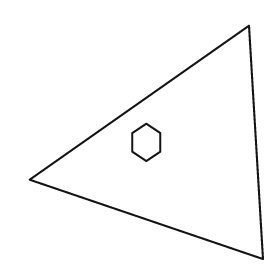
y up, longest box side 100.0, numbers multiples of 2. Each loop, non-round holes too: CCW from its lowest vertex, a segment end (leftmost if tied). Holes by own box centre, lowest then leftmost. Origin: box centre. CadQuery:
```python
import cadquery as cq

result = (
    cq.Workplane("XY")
    .moveTo(50.0, -50.0)
    .lineTo(44.0, 50.0)
    .lineTo(-50.0, -16.0)
    .close()
    .moveTo(0.0, -8.0)
    .lineTo(6.0, -4.0)
    .lineTo(6.0, 4.0)
    .lineTo(0.0, 8.0)
    .lineTo(-6.0, 4.0)
    .lineTo(-6.0, -4.0)
    .close()
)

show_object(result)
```